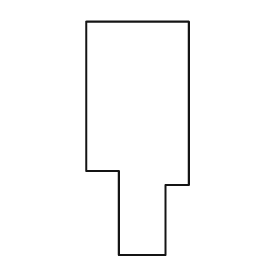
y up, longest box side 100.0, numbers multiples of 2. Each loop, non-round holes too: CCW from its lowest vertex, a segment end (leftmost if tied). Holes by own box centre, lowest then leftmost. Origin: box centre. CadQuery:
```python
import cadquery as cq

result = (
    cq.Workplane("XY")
    .moveTo(-8.0, -50.0)
    .lineTo(12.0, -50.0)
    .lineTo(12.0, -20.0)
    .lineTo(22.0, -20.0)
    .lineTo(22.0, 50.0)
    .lineTo(-22.0, 50.0)
    .lineTo(-22.0, -14.0)
    .lineTo(-8.0, -14.0)
    .close()
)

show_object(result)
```